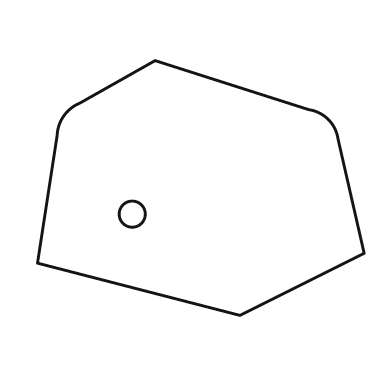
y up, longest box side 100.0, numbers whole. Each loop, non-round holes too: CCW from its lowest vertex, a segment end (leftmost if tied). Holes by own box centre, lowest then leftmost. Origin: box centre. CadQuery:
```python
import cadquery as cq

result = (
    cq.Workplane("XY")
    .moveTo(12.0, -39.0)
    .lineTo(50.0, -20.0)
    .lineTo(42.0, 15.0)
    .threePointArc((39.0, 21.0), (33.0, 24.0))
    .lineTo(-14.0, 39.0)
    .lineTo(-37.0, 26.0)
    .threePointArc((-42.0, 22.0), (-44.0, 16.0))
    .lineTo(-50.0, -23.0)
    .close()
    .moveTo(-21.0, -8.0)
    .circle(4.0)
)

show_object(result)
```